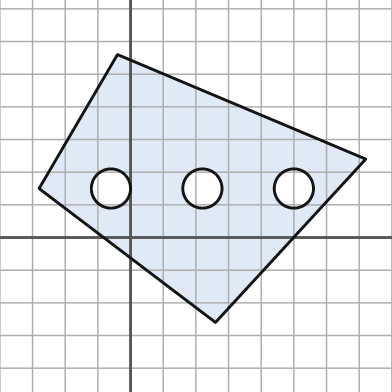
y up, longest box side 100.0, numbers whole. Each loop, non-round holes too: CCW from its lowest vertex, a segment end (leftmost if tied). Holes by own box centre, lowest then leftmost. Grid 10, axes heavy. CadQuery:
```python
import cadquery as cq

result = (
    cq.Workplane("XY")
    .moveTo(26.0, -26.0)
    .lineTo(72.0, 24.0)
    .lineTo(-4.0, 56.0)
    .lineTo(-28.0, 15.0)
    .close()
    .moveTo(-6.0, 15.0)
    .circle(6.0)
    .moveTo(22.0, 15.0)
    .circle(6.0)
    .moveTo(50.0, 15.0)
    .circle(6.0)
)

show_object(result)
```